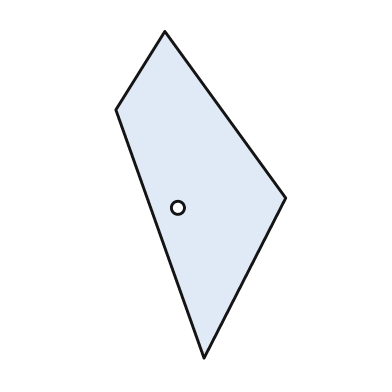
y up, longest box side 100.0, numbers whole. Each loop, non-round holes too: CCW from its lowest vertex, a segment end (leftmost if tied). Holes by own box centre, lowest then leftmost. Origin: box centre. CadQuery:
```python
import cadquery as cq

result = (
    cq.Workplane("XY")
    .moveTo(1.0, -50.0)
    .lineTo(26.0, -1.0)
    .lineTo(-11.0, 50.0)
    .lineTo(-26.0, 26.0)
    .close()
    .moveTo(-7.0, -4.0)
    .circle(2.0)
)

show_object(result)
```